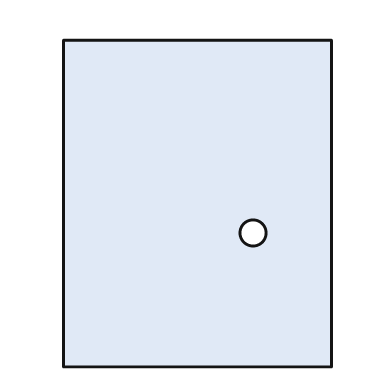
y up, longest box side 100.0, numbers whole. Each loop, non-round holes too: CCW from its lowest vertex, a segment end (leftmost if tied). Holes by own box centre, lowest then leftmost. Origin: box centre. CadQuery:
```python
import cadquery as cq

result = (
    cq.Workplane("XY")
    .moveTo(-41.0, -50.0)
    .lineTo(41.0, -50.0)
    .lineTo(41.0, 50.0)
    .lineTo(-41.0, 50.0)
    .close()
    .moveTo(17.0, -9.0)
    .circle(4.0)
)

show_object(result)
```